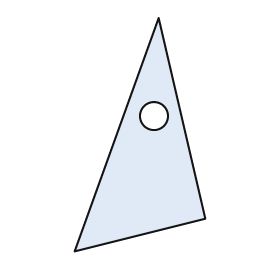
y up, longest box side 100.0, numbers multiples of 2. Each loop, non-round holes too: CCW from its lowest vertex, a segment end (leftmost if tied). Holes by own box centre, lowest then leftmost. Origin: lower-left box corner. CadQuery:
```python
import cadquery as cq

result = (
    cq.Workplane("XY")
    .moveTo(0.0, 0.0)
    .lineTo(56.0, 14.0)
    .lineTo(36.0, 100.0)
    .close()
    .moveTo(34.0, 58.0)
    .circle(6.0)
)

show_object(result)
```